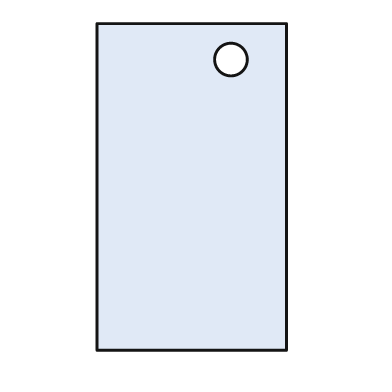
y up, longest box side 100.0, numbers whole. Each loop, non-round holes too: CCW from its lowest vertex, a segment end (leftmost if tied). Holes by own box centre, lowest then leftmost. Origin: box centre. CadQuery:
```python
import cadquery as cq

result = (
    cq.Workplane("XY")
    .moveTo(-29.0, -50.0)
    .lineTo(29.0, -50.0)
    .lineTo(29.0, 50.0)
    .lineTo(-29.0, 50.0)
    .close()
    .moveTo(12.0, 39.0)
    .circle(5.0)
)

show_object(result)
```